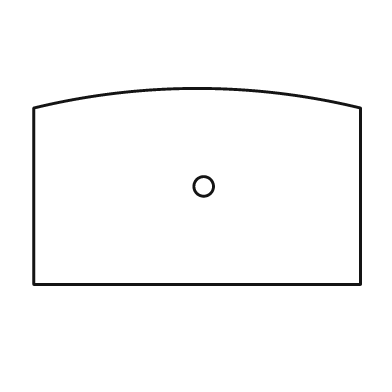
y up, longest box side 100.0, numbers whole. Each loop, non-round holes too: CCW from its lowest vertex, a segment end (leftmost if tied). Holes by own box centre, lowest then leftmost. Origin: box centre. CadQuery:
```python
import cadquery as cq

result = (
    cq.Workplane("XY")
    .moveTo(-50.0, -30.0)
    .lineTo(50.0, -30.0)
    .lineTo(50.0, 24.0)
    .threePointArc((0.0, 30.0), (-50.0, 24.0))
    .close()
    .moveTo(2.0, 0.0)
    .circle(3.0)
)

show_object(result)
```